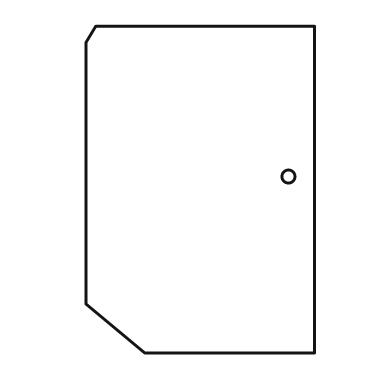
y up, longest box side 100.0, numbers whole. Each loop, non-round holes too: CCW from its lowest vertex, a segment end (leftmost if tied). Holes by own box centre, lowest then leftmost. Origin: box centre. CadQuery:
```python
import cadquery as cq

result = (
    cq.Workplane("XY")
    .moveTo(-17.0, -50.0)
    .lineTo(35.0, -50.0)
    .lineTo(35.0, 50.0)
    .lineTo(-32.0, 50.0)
    .lineTo(-35.0, 45.0)
    .lineTo(-35.0, -35.0)
    .close()
    .moveTo(27.0, 4.0)
    .circle(2.0)
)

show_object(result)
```